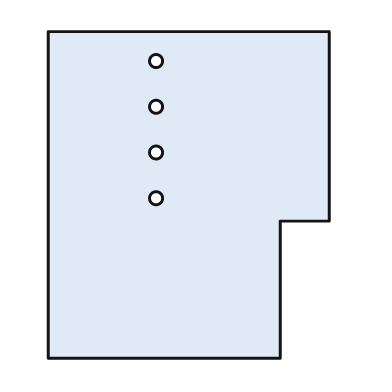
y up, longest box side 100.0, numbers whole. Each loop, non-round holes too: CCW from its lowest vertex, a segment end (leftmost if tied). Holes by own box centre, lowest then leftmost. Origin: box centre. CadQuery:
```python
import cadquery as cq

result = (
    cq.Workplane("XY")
    .moveTo(-43.0, -50.0)
    .lineTo(28.0, -50.0)
    .lineTo(28.0, -8.0)
    .lineTo(43.0, -8.0)
    .lineTo(43.0, 50.0)
    .lineTo(-43.0, 50.0)
    .close()
    .moveTo(-10.0, -1.0)
    .circle(2.0)
    .moveTo(-10.0, 13.0)
    .circle(2.0)
    .moveTo(-10.0, 27.0)
    .circle(2.0)
    .moveTo(-10.0, 41.0)
    .circle(2.0)
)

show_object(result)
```